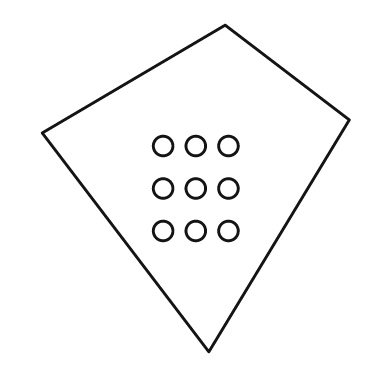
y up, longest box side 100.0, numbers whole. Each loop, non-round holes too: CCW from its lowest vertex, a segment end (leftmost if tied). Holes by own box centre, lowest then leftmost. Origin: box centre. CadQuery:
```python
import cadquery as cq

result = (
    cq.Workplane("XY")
    .moveTo(4.0, -50.0)
    .lineTo(47.0, 21.0)
    .lineTo(9.0, 50.0)
    .lineTo(-47.0, 17.0)
    .close()
    .moveTo(-10.0, -13.0)
    .circle(3.0)
    .moveTo(0.0, -13.0)
    .circle(3.0)
    .moveTo(10.0, -13.0)
    .circle(3.0)
    .moveTo(-10.0, 0.0)
    .circle(3.0)
    .moveTo(0.0, 0.0)
    .circle(3.0)
    .moveTo(10.0, 0.0)
    .circle(3.0)
    .moveTo(-10.0, 13.0)
    .circle(3.0)
    .moveTo(0.0, 13.0)
    .circle(3.0)
    .moveTo(10.0, 13.0)
    .circle(3.0)
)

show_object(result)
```